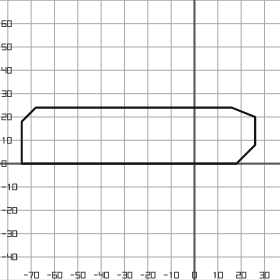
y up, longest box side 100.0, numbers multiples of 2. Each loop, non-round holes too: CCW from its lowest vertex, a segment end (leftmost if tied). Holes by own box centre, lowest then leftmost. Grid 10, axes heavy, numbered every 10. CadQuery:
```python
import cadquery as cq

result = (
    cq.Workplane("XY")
    .moveTo(-74.0, 0.0)
    .lineTo(18.0, 0.0)
    .lineTo(26.0, 8.0)
    .lineTo(26.0, 20.0)
    .lineTo(16.0, 24.0)
    .lineTo(-68.0, 24.0)
    .lineTo(-74.0, 18.0)
    .close()
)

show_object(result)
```